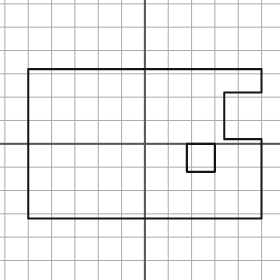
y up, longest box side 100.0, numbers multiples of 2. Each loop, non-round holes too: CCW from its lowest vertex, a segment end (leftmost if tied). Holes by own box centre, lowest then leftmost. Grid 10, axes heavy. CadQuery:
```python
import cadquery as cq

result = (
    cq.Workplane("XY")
    .moveTo(-50.0, -32.0)
    .lineTo(50.0, -32.0)
    .lineTo(50.0, 2.0)
    .lineTo(34.0, 2.0)
    .lineTo(34.0, 22.0)
    .lineTo(50.0, 22.0)
    .lineTo(50.0, 32.0)
    .lineTo(-50.0, 32.0)
    .close()
    .moveTo(18.0, -12.0)
    .lineTo(30.0, -12.0)
    .lineTo(30.0, 0.0)
    .lineTo(18.0, 0.0)
    .close()
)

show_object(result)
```